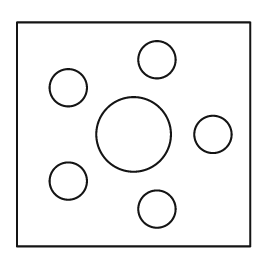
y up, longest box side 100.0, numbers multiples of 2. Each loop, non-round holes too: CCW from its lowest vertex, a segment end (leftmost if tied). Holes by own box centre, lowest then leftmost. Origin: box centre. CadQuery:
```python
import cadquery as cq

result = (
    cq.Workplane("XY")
    .moveTo(-50.0, -48.0)
    .lineTo(50.0, -48.0)
    .lineTo(50.0, 48.0)
    .lineTo(-50.0, 48.0)
    .close()
    .moveTo(10.0, -32.0)
    .circle(8.0)
    .moveTo(-28.0, -20.0)
    .circle(8.0)
    .moveTo(0.0, 0.0)
    .circle(16.0)
    .moveTo(34.0, 0.0)
    .circle(8.0)
    .moveTo(-28.0, 20.0)
    .circle(8.0)
    .moveTo(10.0, 32.0)
    .circle(8.0)
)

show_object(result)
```